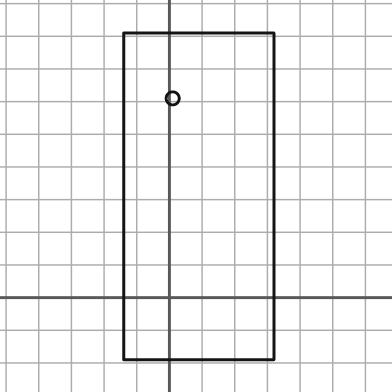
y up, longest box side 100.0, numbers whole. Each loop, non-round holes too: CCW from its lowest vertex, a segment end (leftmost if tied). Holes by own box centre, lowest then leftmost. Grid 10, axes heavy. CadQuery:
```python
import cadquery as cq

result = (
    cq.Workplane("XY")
    .moveTo(-14.0, -19.0)
    .lineTo(32.0, -19.0)
    .lineTo(32.0, 81.0)
    .lineTo(-14.0, 81.0)
    .close()
    .moveTo(1.0, 61.0)
    .circle(2.0)
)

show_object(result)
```